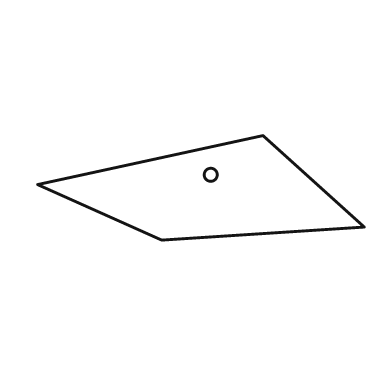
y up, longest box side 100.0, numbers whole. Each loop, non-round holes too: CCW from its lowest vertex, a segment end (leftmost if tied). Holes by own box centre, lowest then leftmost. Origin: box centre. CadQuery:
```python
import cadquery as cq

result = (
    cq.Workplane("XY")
    .moveTo(-12.0, -16.0)
    .lineTo(50.0, -12.0)
    .lineTo(19.0, 16.0)
    .lineTo(-50.0, 1.0)
    .close()
    .moveTo(3.0, 4.0)
    .circle(2.0)
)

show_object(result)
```